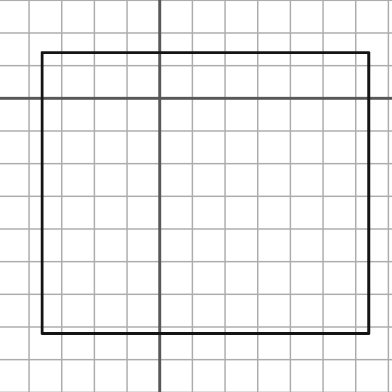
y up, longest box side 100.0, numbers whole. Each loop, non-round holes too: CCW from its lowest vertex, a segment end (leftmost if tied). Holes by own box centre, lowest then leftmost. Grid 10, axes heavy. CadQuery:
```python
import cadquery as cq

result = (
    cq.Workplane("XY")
    .moveTo(-36.0, -72.0)
    .lineTo(64.0, -72.0)
    .lineTo(64.0, 14.0)
    .lineTo(-36.0, 14.0)
    .close()
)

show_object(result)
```